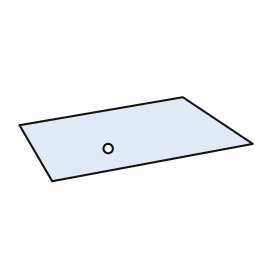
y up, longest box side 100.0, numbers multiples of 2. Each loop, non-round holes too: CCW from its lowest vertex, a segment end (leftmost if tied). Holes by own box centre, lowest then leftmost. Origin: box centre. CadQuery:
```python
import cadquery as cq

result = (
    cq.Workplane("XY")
    .moveTo(-36.0, -18.0)
    .lineTo(50.0, -2.0)
    .lineTo(20.0, 18.0)
    .lineTo(-50.0, 6.0)
    .close()
    .moveTo(-12.0, -4.0)
    .circle(2.0)
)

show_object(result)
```